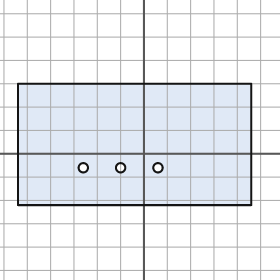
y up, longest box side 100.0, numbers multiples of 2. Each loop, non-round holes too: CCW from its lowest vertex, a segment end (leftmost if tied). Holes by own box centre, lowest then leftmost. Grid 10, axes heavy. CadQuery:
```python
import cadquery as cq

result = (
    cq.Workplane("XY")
    .moveTo(-54.0, -22.0)
    .lineTo(46.0, -22.0)
    .lineTo(46.0, 30.0)
    .lineTo(-54.0, 30.0)
    .close()
    .moveTo(-26.0, -6.0)
    .circle(2.0)
    .moveTo(-10.0, -6.0)
    .circle(2.0)
    .moveTo(6.0, -6.0)
    .circle(2.0)
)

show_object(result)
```